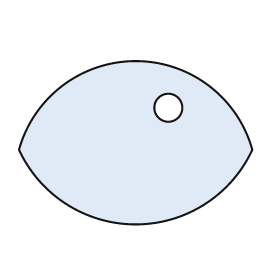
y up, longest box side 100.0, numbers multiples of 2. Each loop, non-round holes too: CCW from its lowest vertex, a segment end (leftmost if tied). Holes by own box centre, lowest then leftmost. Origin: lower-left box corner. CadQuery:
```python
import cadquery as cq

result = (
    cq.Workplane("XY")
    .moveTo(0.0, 32.0)
    .threePointArc((50.0, 0.0), (100.0, 32.0))
    .threePointArc((50.0, 70.0), (0.0, 32.0))
    .close()
    .moveTo(64.0, 50.0)
    .circle(6.0)
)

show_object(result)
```